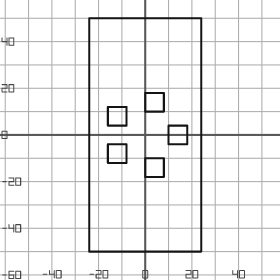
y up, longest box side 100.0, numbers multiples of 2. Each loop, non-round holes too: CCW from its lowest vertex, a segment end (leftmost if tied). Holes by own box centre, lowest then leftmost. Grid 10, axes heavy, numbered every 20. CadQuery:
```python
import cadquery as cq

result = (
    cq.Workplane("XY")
    .moveTo(-24.0, -50.0)
    .lineTo(24.0, -50.0)
    .lineTo(24.0, 50.0)
    .lineTo(-24.0, 50.0)
    .close()
    .moveTo(0.0, -18.0)
    .lineTo(8.0, -18.0)
    .lineTo(8.0, -10.0)
    .lineTo(0.0, -10.0)
    .close()
    .moveTo(-16.0, -12.0)
    .lineTo(-8.0, -12.0)
    .lineTo(-8.0, -4.0)
    .lineTo(-16.0, -4.0)
    .close()
    .moveTo(10.0, -4.0)
    .lineTo(18.0, -4.0)
    .lineTo(18.0, 4.0)
    .lineTo(10.0, 4.0)
    .close()
    .moveTo(-16.0, 4.0)
    .lineTo(-8.0, 4.0)
    .lineTo(-8.0, 12.0)
    .lineTo(-16.0, 12.0)
    .close()
    .moveTo(0.0, 10.0)
    .lineTo(8.0, 10.0)
    .lineTo(8.0, 18.0)
    .lineTo(0.0, 18.0)
    .close()
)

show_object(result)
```